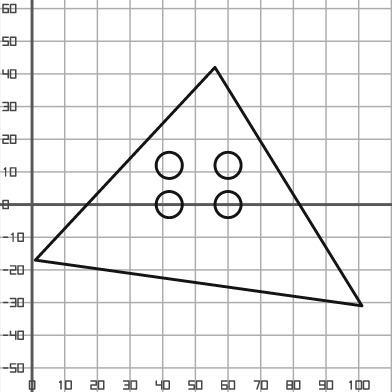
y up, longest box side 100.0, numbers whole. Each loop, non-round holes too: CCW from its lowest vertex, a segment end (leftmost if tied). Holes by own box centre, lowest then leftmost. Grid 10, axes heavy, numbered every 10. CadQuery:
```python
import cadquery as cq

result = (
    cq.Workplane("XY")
    .moveTo(101.0, -31.0)
    .lineTo(56.0, 42.0)
    .lineTo(1.0, -17.0)
    .close()
    .moveTo(42.0, 0.0)
    .circle(4.0)
    .moveTo(60.0, 0.0)
    .circle(4.0)
    .moveTo(42.0, 12.0)
    .circle(4.0)
    .moveTo(60.0, 12.0)
    .circle(4.0)
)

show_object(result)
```